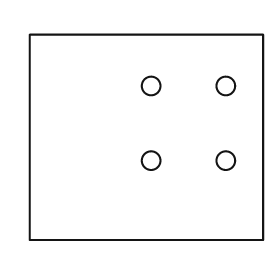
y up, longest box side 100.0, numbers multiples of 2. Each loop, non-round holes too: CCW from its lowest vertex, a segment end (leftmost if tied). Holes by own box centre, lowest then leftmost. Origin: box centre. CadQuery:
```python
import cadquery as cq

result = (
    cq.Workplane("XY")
    .moveTo(-50.0, -44.0)
    .lineTo(50.0, -44.0)
    .lineTo(50.0, 44.0)
    .lineTo(-50.0, 44.0)
    .close()
    .moveTo(2.0, -10.0)
    .circle(4.0)
    .moveTo(34.0, -10.0)
    .circle(4.0)
    .moveTo(2.0, 22.0)
    .circle(4.0)
    .moveTo(34.0, 22.0)
    .circle(4.0)
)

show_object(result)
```